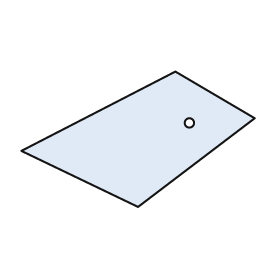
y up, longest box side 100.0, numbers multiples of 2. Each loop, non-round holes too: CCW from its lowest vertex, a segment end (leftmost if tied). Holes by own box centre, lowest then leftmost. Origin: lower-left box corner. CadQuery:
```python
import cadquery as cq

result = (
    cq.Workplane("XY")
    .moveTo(50.0, 0.0)
    .lineTo(100.0, 38.0)
    .lineTo(66.0, 58.0)
    .lineTo(0.0, 24.0)
    .close()
    .moveTo(72.0, 36.0)
    .circle(2.0)
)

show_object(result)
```